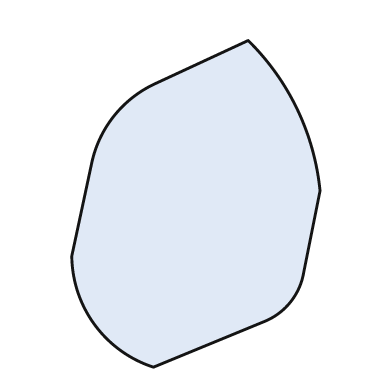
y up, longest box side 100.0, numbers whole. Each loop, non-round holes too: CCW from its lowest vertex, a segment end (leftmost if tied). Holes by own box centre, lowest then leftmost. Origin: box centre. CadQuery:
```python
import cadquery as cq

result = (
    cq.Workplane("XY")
    .moveTo(-13.0, -50.0)
    .lineTo(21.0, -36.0)
    .threePointArc((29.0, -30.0), (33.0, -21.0))
    .lineTo(38.0, 4.0)
    .threePointArc((31.0, 29.0), (16.0, 50.0))
    .lineTo(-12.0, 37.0)
    .threePointArc((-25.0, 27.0), (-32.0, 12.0))
    .lineTo(-38.0, -16.0)
    .threePointArc((-31.0, -37.0), (-13.0, -50.0))
    .close()
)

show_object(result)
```